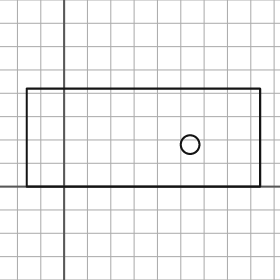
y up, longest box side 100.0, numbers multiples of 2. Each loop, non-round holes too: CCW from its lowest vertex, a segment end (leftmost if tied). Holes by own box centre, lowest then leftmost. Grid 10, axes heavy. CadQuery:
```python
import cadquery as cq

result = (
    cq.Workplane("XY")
    .moveTo(-16.0, 0.0)
    .lineTo(84.0, 0.0)
    .lineTo(84.0, 42.0)
    .lineTo(-16.0, 42.0)
    .close()
    .moveTo(54.0, 18.0)
    .circle(4.0)
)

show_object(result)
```